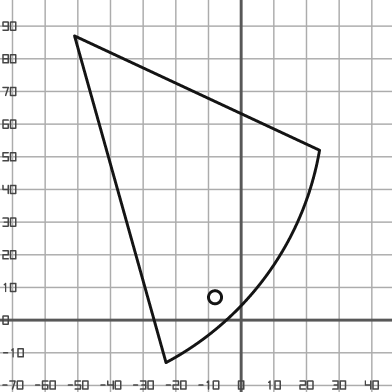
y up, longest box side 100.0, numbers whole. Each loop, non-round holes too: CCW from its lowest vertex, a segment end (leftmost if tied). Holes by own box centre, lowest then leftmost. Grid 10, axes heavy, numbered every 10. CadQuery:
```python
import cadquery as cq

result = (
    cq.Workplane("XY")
    .moveTo(-23.0, -13.0)
    .threePointArc((8.0, 14.0), (24.0, 52.0))
    .lineTo(-51.0, 87.0)
    .close()
    .moveTo(-8.0, 7.0)
    .circle(2.0)
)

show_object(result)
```